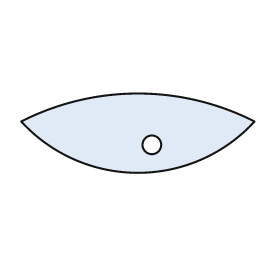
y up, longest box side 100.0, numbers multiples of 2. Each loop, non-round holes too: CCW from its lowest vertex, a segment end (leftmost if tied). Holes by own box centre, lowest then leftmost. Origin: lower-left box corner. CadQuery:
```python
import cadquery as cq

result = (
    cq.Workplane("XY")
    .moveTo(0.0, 22.0)
    .threePointArc((50.0, 0.0), (100.0, 22.0))
    .threePointArc((50.0, 34.0), (0.0, 22.0))
    .close()
    .moveTo(56.0, 12.0)
    .circle(4.0)
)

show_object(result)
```